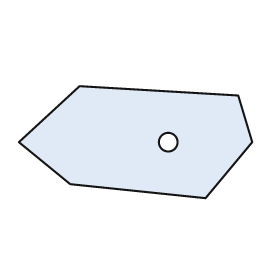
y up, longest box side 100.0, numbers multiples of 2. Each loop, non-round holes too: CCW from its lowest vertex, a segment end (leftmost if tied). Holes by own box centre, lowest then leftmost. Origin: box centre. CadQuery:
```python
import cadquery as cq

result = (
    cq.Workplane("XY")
    .moveTo(30.0, -24.0)
    .lineTo(50.0, 0.0)
    .lineTo(44.0, 20.0)
    .lineTo(-24.0, 24.0)
    .lineTo(-50.0, 0.0)
    .lineTo(-28.0, -18.0)
    .close()
    .moveTo(14.0, 0.0)
    .circle(4.0)
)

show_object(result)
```